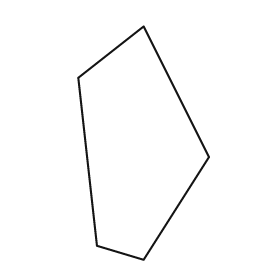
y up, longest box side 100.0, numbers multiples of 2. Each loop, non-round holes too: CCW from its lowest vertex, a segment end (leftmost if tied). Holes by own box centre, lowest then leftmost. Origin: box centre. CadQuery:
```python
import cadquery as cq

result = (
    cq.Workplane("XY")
    .moveTo(0.0, -50.0)
    .lineTo(28.0, -6.0)
    .lineTo(0.0, 50.0)
    .lineTo(-28.0, 28.0)
    .lineTo(-20.0, -44.0)
    .close()
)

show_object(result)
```